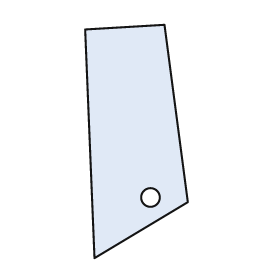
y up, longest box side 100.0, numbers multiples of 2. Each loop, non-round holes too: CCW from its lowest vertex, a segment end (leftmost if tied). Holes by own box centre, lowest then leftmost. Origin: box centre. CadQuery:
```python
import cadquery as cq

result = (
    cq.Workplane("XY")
    .moveTo(-18.0, -50.0)
    .lineTo(22.0, -26.0)
    .lineTo(12.0, 50.0)
    .lineTo(-22.0, 48.0)
    .close()
    .moveTo(6.0, -24.0)
    .circle(4.0)
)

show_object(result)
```